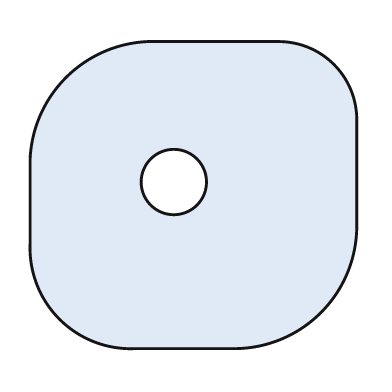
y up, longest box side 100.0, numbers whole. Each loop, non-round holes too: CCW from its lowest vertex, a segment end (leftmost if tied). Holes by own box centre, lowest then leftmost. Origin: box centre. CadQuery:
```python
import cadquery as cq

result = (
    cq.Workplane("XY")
    .moveTo(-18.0, -47.0)
    .lineTo(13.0, -47.0)
    .threePointArc((39.0, -36.0), (50.0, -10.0))
    .lineTo(50.0, 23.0)
    .threePointArc((43.0, 40.0), (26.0, 47.0))
    .lineTo(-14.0, 47.0)
    .threePointArc((-39.0, 36.0), (-50.0, 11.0))
    .lineTo(-50.0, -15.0)
    .threePointArc((-41.0, -38.0), (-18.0, -47.0))
    .close()
    .moveTo(-6.0, 4.0)
    .circle(10.0)
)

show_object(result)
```